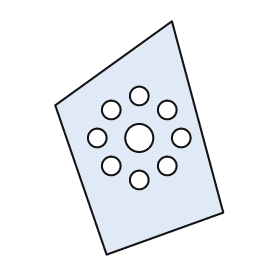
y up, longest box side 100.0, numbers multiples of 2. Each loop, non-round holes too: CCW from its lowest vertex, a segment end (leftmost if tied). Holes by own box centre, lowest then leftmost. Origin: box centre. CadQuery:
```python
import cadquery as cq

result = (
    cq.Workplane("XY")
    .moveTo(-14.0, -50.0)
    .lineTo(36.0, -32.0)
    .lineTo(14.0, 50.0)
    .lineTo(-36.0, 14.0)
    .close()
    .moveTo(0.0, -18.0)
    .circle(4.0)
    .moveTo(-12.0, -12.0)
    .circle(4.0)
    .moveTo(12.0, -12.0)
    .circle(4.0)
    .moveTo(-18.0, 0.0)
    .circle(4.0)
    .moveTo(0.0, 0.0)
    .circle(6.0)
    .moveTo(18.0, 0.0)
    .circle(4.0)
    .moveTo(-12.0, 12.0)
    .circle(4.0)
    .moveTo(12.0, 12.0)
    .circle(4.0)
    .moveTo(0.0, 18.0)
    .circle(4.0)
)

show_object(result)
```